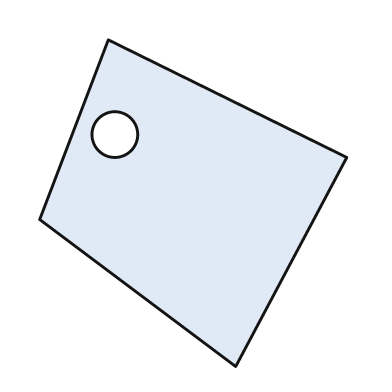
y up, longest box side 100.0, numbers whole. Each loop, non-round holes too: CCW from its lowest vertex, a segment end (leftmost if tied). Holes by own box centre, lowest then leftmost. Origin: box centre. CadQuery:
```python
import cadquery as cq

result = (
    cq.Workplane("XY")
    .moveTo(13.0, -50.0)
    .lineTo(47.0, 14.0)
    .lineTo(-26.0, 50.0)
    .lineTo(-47.0, -5.0)
    .close()
    .moveTo(-24.0, 21.0)
    .circle(7.0)
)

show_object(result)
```